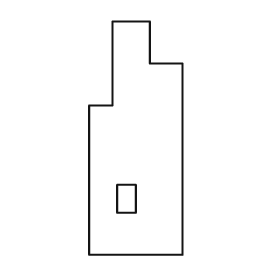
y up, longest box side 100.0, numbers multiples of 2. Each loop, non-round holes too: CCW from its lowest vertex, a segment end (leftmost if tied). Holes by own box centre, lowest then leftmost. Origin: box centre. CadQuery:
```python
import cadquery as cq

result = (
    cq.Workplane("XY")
    .moveTo(-20.0, -50.0)
    .lineTo(20.0, -50.0)
    .lineTo(20.0, 32.0)
    .lineTo(6.0, 32.0)
    .lineTo(6.0, 50.0)
    .lineTo(-10.0, 50.0)
    .lineTo(-10.0, 14.0)
    .lineTo(-20.0, 14.0)
    .close()
    .moveTo(-8.0, -32.0)
    .lineTo(0.0, -32.0)
    .lineTo(0.0, -20.0)
    .lineTo(-8.0, -20.0)
    .close()
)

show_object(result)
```